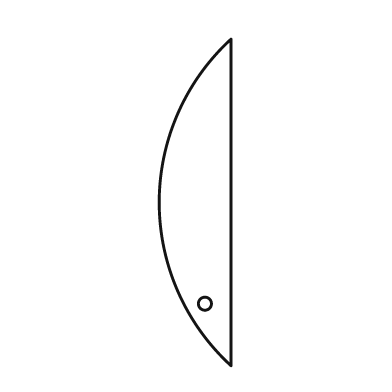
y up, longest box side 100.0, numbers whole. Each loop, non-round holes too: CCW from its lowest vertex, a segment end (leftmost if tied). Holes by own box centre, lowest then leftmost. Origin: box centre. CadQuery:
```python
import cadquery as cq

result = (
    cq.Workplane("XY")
    .moveTo(11.0, -50.0)
    .lineTo(11.0, 50.0)
    .threePointArc((-11.0, 0.0), (11.0, -50.0))
    .close()
    .moveTo(3.0, -31.0)
    .circle(2.0)
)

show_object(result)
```